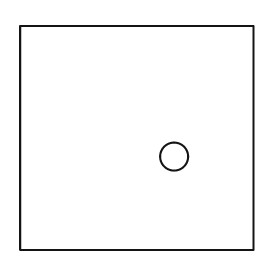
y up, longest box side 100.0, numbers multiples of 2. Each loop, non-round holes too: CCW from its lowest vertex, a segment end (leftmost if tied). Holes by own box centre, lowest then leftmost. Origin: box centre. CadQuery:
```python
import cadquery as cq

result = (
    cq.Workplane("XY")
    .moveTo(-50.0, -48.0)
    .lineTo(50.0, -48.0)
    .lineTo(50.0, 48.0)
    .lineTo(-50.0, 48.0)
    .close()
    .moveTo(16.0, -8.0)
    .circle(6.0)
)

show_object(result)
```